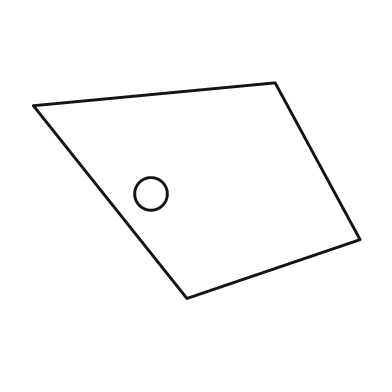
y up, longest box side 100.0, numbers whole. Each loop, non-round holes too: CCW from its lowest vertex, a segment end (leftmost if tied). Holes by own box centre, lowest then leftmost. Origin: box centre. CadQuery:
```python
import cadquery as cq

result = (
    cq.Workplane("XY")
    .moveTo(-3.0, -33.0)
    .lineTo(50.0, -15.0)
    .lineTo(24.0, 33.0)
    .lineTo(-50.0, 26.0)
    .close()
    .moveTo(-14.0, -1.0)
    .circle(5.0)
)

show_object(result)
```